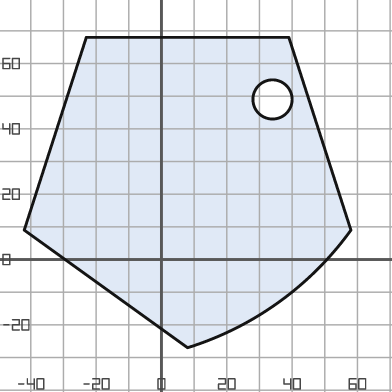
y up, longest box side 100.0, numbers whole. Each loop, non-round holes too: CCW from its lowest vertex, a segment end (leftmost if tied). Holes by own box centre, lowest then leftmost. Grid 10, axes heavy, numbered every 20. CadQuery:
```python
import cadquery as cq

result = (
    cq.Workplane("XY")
    .moveTo(8.0, -27.0)
    .threePointArc((36.0, -13.0), (58.0, 9.0))
    .lineTo(39.0, 68.0)
    .lineTo(-23.0, 68.0)
    .lineTo(-42.0, 9.0)
    .close()
    .moveTo(34.0, 49.0)
    .circle(6.0)
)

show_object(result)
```